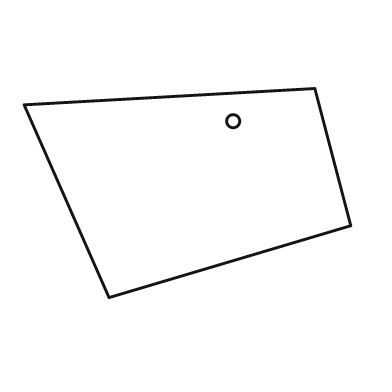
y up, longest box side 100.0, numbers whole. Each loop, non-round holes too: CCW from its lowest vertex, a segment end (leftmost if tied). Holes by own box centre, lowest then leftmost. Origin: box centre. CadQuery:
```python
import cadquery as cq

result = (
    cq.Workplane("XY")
    .moveTo(-24.0, -32.0)
    .lineTo(50.0, -10.0)
    .lineTo(39.0, 32.0)
    .lineTo(-50.0, 27.0)
    .close()
    .moveTo(14.0, 22.0)
    .circle(2.0)
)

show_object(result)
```